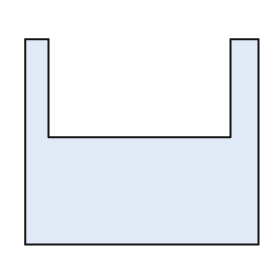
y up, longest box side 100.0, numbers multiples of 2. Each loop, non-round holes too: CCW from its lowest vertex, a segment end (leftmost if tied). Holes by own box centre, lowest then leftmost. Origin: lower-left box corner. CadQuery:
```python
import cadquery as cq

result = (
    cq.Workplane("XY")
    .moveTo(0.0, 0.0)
    .lineTo(100.0, 0.0)
    .lineTo(100.0, 88.0)
    .lineTo(88.0, 88.0)
    .lineTo(88.0, 46.0)
    .lineTo(10.0, 46.0)
    .lineTo(10.0, 88.0)
    .lineTo(0.0, 88.0)
    .close()
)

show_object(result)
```